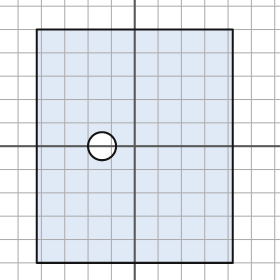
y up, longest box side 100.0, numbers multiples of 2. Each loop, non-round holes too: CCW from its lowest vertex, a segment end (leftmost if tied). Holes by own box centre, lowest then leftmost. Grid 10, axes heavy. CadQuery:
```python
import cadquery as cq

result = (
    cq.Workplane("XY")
    .moveTo(-42.0, -50.0)
    .lineTo(42.0, -50.0)
    .lineTo(42.0, 50.0)
    .lineTo(-42.0, 50.0)
    .close()
    .moveTo(-14.0, 0.0)
    .circle(6.0)
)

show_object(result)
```